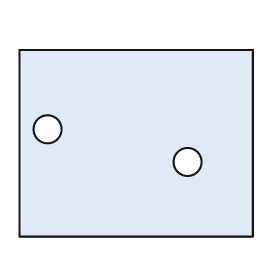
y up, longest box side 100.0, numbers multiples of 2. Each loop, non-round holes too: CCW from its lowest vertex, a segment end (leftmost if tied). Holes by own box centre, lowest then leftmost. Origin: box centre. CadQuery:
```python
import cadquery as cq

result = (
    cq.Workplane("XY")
    .moveTo(-50.0, -40.0)
    .lineTo(50.0, -40.0)
    .lineTo(50.0, 40.0)
    .lineTo(-50.0, 40.0)
    .close()
    .moveTo(22.0, -8.0)
    .circle(6.0)
    .moveTo(-38.0, 6.0)
    .circle(6.0)
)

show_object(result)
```